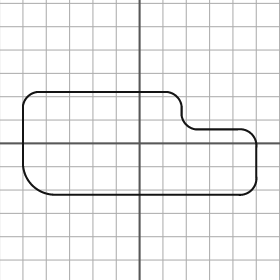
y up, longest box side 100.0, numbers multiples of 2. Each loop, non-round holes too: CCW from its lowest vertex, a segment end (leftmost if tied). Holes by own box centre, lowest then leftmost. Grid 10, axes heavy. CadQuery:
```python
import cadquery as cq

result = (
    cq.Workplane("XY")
    .moveTo(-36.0, -22.0)
    .lineTo(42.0, -22.0)
    .threePointArc((48.0, -20.0), (50.0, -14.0))
    .lineTo(50.0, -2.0)
    .threePointArc((48.0, 4.0), (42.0, 6.0))
    .lineTo(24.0, 6.0)
    .threePointArc((20.0, 8.0), (18.0, 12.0))
    .lineTo(18.0, 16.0)
    .threePointArc((16.0, 20.0), (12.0, 22.0))
    .lineTo(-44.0, 22.0)
    .threePointArc((-48.0, 20.0), (-50.0, 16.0))
    .lineTo(-50.0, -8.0)
    .threePointArc((-46.0, -18.0), (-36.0, -22.0))
    .close()
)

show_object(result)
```